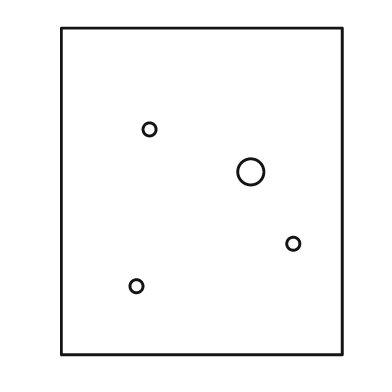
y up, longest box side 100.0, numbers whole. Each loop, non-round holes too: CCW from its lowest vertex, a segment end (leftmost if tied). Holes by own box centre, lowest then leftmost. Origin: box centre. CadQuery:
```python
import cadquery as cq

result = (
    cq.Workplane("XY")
    .moveTo(-43.0, -50.0)
    .lineTo(43.0, -50.0)
    .lineTo(43.0, 50.0)
    .lineTo(-43.0, 50.0)
    .close()
    .moveTo(-20.0, -29.0)
    .circle(2.0)
    .moveTo(28.0, -16.0)
    .circle(2.0)
    .moveTo(15.0, 6.0)
    .circle(4.0)
    .moveTo(-16.0, 19.0)
    .circle(2.0)
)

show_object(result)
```